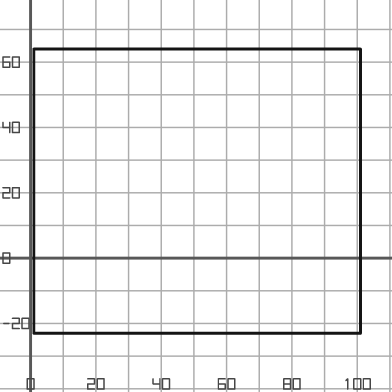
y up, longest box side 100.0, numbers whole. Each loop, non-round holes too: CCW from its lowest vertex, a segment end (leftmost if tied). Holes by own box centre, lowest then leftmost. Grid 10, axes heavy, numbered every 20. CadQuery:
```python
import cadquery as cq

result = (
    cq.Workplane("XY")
    .moveTo(1.0, -23.0)
    .lineTo(101.0, -23.0)
    .lineTo(101.0, 64.0)
    .lineTo(1.0, 64.0)
    .close()
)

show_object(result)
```